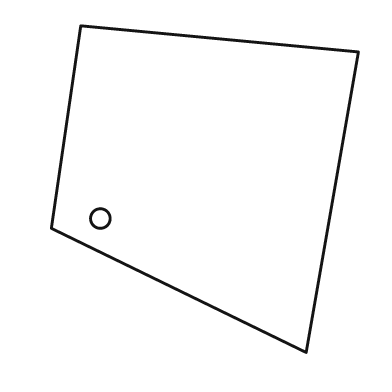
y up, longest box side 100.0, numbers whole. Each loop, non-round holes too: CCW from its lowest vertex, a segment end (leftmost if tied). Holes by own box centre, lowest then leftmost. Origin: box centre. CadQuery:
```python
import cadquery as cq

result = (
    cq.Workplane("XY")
    .moveTo(31.0, -50.0)
    .lineTo(47.0, 42.0)
    .lineTo(-38.0, 50.0)
    .lineTo(-47.0, -12.0)
    .close()
    .moveTo(-32.0, -9.0)
    .circle(3.0)
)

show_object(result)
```